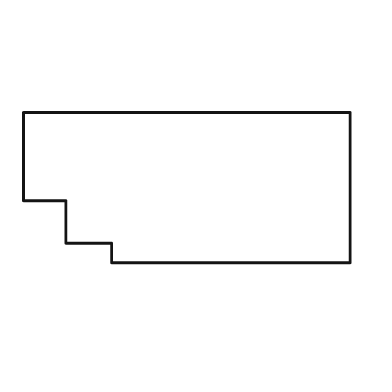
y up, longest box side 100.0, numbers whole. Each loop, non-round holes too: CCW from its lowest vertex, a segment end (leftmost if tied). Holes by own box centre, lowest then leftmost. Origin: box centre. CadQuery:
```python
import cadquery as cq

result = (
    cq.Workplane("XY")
    .moveTo(-23.0, -23.0)
    .lineTo(50.0, -23.0)
    .lineTo(50.0, 23.0)
    .lineTo(-50.0, 23.0)
    .lineTo(-50.0, -4.0)
    .lineTo(-37.0, -4.0)
    .lineTo(-37.0, -17.0)
    .lineTo(-23.0, -17.0)
    .close()
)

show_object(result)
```